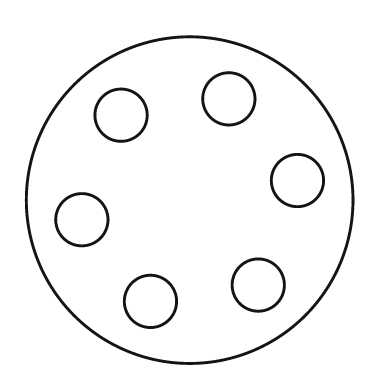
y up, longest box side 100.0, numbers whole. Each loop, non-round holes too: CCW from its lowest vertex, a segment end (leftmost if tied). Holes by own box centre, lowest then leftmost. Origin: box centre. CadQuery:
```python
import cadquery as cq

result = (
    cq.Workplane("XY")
    .moveTo(0.0, 0.0)
    .circle(50.0)
    .moveTo(-12.0, -31.0)
    .circle(8.0)
    .moveTo(21.0, -26.0)
    .circle(8.0)
    .moveTo(-33.0, -6.0)
    .circle(8.0)
    .moveTo(33.0, 6.0)
    .circle(8.0)
    .moveTo(-21.0, 26.0)
    .circle(8.0)
    .moveTo(12.0, 31.0)
    .circle(8.0)
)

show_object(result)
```